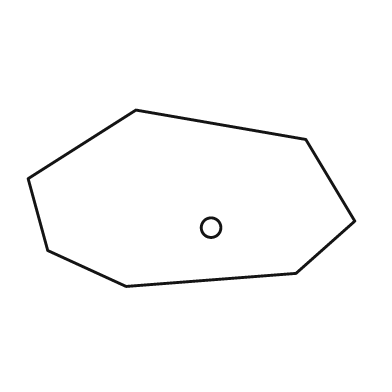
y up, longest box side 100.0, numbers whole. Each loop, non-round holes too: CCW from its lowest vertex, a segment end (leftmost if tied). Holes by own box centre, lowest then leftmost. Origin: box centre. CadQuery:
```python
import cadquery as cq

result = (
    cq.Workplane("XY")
    .moveTo(-20.0, -27.0)
    .lineTo(32.0, -23.0)
    .lineTo(50.0, -7.0)
    .lineTo(35.0, 18.0)
    .lineTo(-17.0, 27.0)
    .lineTo(-50.0, 6.0)
    .lineTo(-44.0, -16.0)
    .close()
    .moveTo(6.0, -9.0)
    .circle(3.0)
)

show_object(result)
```